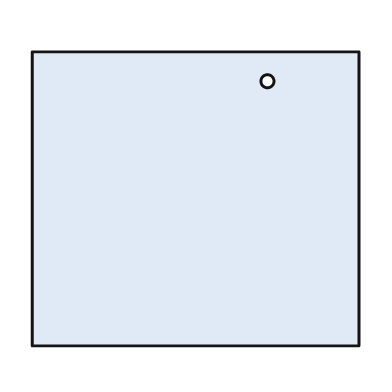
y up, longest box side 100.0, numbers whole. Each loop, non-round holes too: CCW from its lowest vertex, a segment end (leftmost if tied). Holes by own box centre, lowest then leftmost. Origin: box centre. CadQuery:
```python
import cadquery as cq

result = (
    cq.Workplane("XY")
    .moveTo(-50.0, -45.0)
    .lineTo(50.0, -45.0)
    .lineTo(50.0, 45.0)
    .lineTo(-50.0, 45.0)
    .close()
    .moveTo(22.0, 36.0)
    .circle(2.0)
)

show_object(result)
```